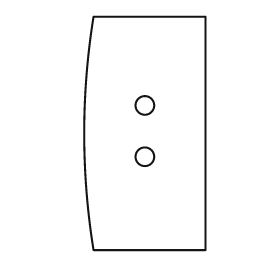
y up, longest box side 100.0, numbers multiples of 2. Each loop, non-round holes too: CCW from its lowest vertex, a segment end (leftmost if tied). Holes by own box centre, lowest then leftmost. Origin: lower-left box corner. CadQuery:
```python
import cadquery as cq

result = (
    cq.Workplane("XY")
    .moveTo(4.0, 0.0)
    .lineTo(52.0, 0.0)
    .lineTo(52.0, 100.0)
    .lineTo(4.0, 100.0)
    .threePointArc((0.0, 50.0), (4.0, 0.0))
    .close()
    .moveTo(26.0, 40.0)
    .circle(4.0)
    .moveTo(26.0, 62.0)
    .circle(4.0)
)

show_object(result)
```